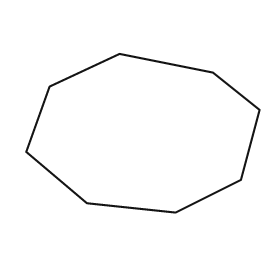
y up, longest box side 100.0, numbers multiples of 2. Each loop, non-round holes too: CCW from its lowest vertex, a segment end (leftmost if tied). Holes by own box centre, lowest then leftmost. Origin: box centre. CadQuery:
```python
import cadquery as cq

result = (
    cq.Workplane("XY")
    .moveTo(14.0, -34.0)
    .lineTo(42.0, -20.0)
    .lineTo(50.0, 10.0)
    .lineTo(30.0, 26.0)
    .lineTo(-10.0, 34.0)
    .lineTo(-40.0, 20.0)
    .lineTo(-50.0, -8.0)
    .lineTo(-24.0, -30.0)
    .close()
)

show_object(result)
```